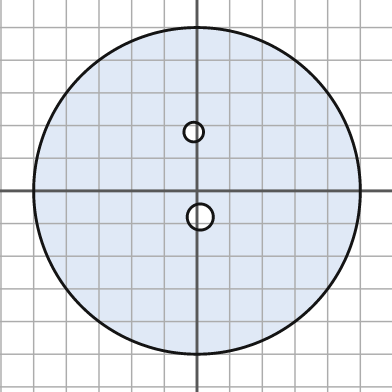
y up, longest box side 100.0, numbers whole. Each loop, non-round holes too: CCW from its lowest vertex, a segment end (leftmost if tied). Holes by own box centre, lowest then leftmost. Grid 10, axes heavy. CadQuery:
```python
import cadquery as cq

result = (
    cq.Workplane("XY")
    .moveTo(0.0, 0.0)
    .circle(50.0)
    .moveTo(1.0, -8.0)
    .circle(4.0)
    .moveTo(-1.0, 18.0)
    .circle(3.0)
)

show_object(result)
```